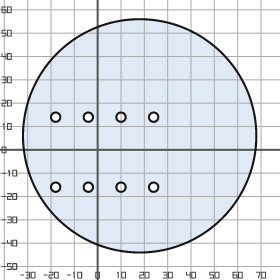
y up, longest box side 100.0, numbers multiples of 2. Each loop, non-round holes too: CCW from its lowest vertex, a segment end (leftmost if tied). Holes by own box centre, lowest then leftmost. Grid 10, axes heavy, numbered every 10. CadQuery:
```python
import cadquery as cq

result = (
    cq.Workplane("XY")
    .moveTo(18.0, 6.0)
    .circle(50.0)
    .moveTo(-18.0, -16.0)
    .circle(2.0)
    .moveTo(-4.0, -16.0)
    .circle(2.0)
    .moveTo(10.0, -16.0)
    .circle(2.0)
    .moveTo(24.0, -16.0)
    .circle(2.0)
    .moveTo(-18.0, 14.0)
    .circle(2.0)
    .moveTo(-4.0, 14.0)
    .circle(2.0)
    .moveTo(10.0, 14.0)
    .circle(2.0)
    .moveTo(24.0, 14.0)
    .circle(2.0)
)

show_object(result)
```